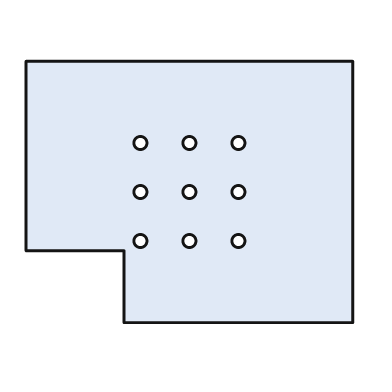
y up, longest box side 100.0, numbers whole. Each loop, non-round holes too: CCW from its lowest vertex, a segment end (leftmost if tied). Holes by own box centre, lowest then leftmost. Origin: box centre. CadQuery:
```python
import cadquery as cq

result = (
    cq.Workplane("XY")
    .moveTo(-20.0, -40.0)
    .lineTo(50.0, -40.0)
    .lineTo(50.0, 40.0)
    .lineTo(-50.0, 40.0)
    .lineTo(-50.0, -18.0)
    .lineTo(-20.0, -18.0)
    .close()
    .moveTo(-15.0, -15.0)
    .circle(2.0)
    .moveTo(0.0, -15.0)
    .circle(2.0)
    .moveTo(15.0, -15.0)
    .circle(2.0)
    .moveTo(-15.0, 0.0)
    .circle(2.0)
    .moveTo(0.0, 0.0)
    .circle(2.0)
    .moveTo(15.0, 0.0)
    .circle(2.0)
    .moveTo(-15.0, 15.0)
    .circle(2.0)
    .moveTo(0.0, 15.0)
    .circle(2.0)
    .moveTo(15.0, 15.0)
    .circle(2.0)
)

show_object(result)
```